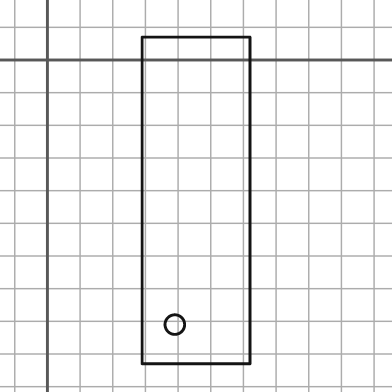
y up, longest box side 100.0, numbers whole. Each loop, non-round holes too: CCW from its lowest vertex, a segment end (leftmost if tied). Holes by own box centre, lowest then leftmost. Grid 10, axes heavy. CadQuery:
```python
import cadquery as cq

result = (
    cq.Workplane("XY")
    .moveTo(29.0, -93.0)
    .lineTo(62.0, -93.0)
    .lineTo(62.0, 7.0)
    .lineTo(29.0, 7.0)
    .close()
    .moveTo(39.0, -81.0)
    .circle(3.0)
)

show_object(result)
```